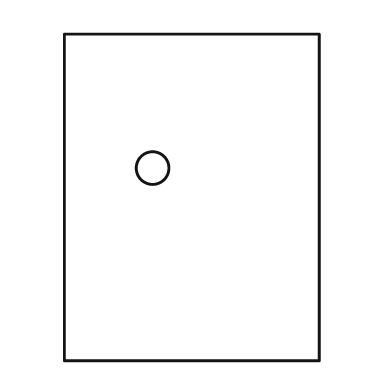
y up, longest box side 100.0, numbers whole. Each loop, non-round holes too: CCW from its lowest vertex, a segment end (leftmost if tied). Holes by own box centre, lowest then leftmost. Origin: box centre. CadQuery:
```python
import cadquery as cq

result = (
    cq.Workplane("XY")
    .moveTo(-39.0, -50.0)
    .lineTo(39.0, -50.0)
    .lineTo(39.0, 50.0)
    .lineTo(-39.0, 50.0)
    .close()
    .moveTo(-12.0, 9.0)
    .circle(5.0)
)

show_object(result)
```